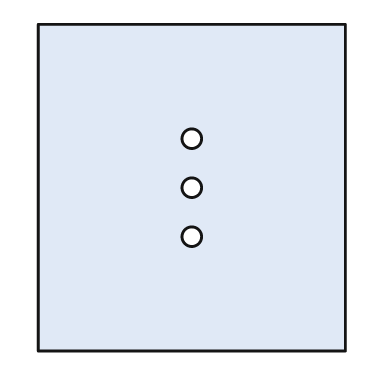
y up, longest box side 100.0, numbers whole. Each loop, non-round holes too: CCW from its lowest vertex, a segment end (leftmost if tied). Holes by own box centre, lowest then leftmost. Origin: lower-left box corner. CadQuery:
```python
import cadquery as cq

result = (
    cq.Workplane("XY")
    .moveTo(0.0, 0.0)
    .lineTo(94.0, 0.0)
    .lineTo(94.0, 100.0)
    .lineTo(0.0, 100.0)
    .close()
    .moveTo(47.0, 35.0)
    .circle(3.0)
    .moveTo(47.0, 50.0)
    .circle(3.0)
    .moveTo(47.0, 65.0)
    .circle(3.0)
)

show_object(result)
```